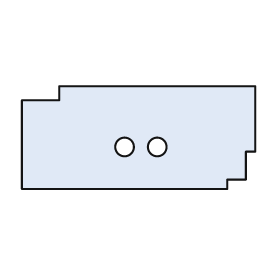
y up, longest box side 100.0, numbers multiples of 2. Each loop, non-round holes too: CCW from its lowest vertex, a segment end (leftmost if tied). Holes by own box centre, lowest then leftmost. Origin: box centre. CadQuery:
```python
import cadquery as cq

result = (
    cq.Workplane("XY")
    .moveTo(-50.0, -22.0)
    .lineTo(38.0, -22.0)
    .lineTo(38.0, -18.0)
    .lineTo(46.0, -18.0)
    .lineTo(46.0, -6.0)
    .lineTo(50.0, -6.0)
    .lineTo(50.0, 22.0)
    .lineTo(-34.0, 22.0)
    .lineTo(-34.0, 16.0)
    .lineTo(-50.0, 16.0)
    .close()
    .moveTo(-6.0, -4.0)
    .circle(4.0)
    .moveTo(8.0, -4.0)
    .circle(4.0)
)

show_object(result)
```